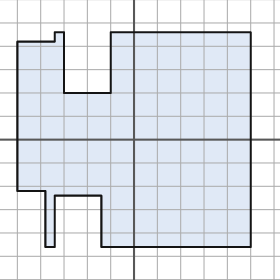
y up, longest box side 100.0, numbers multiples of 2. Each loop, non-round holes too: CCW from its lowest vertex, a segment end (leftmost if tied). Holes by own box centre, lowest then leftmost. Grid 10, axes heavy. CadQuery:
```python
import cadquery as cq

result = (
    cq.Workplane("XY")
    .moveTo(-38.0, -46.0)
    .lineTo(-34.0, -46.0)
    .lineTo(-34.0, -24.0)
    .lineTo(-14.0, -24.0)
    .lineTo(-14.0, -46.0)
    .lineTo(50.0, -46.0)
    .lineTo(50.0, 46.0)
    .lineTo(-10.0, 46.0)
    .lineTo(-10.0, 20.0)
    .lineTo(-30.0, 20.0)
    .lineTo(-30.0, 46.0)
    .lineTo(-34.0, 46.0)
    .lineTo(-34.0, 42.0)
    .lineTo(-50.0, 42.0)
    .lineTo(-50.0, -22.0)
    .lineTo(-38.0, -22.0)
    .close()
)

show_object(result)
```